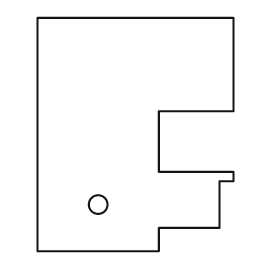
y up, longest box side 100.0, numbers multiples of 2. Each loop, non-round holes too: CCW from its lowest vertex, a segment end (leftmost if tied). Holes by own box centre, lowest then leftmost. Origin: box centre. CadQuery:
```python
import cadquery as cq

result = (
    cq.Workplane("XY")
    .moveTo(-42.0, -50.0)
    .lineTo(10.0, -50.0)
    .lineTo(10.0, -40.0)
    .lineTo(36.0, -40.0)
    .lineTo(36.0, -20.0)
    .lineTo(42.0, -20.0)
    .lineTo(42.0, -16.0)
    .lineTo(10.0, -16.0)
    .lineTo(10.0, 10.0)
    .lineTo(42.0, 10.0)
    .lineTo(42.0, 50.0)
    .lineTo(-42.0, 50.0)
    .close()
    .moveTo(-16.0, -30.0)
    .circle(4.0)
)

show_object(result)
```